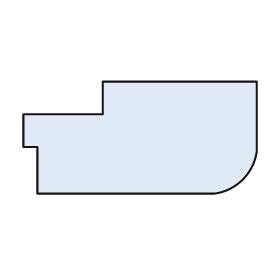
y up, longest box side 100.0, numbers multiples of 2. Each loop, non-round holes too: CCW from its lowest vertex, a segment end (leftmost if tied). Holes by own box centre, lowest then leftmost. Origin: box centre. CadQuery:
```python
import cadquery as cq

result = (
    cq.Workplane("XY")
    .moveTo(-44.0, -24.0)
    .lineTo(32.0, -24.0)
    .threePointArc((44.0, -18.0), (50.0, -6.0))
    .lineTo(50.0, 24.0)
    .lineTo(-16.0, 24.0)
    .lineTo(-16.0, 10.0)
    .lineTo(-50.0, 10.0)
    .lineTo(-50.0, -4.0)
    .lineTo(-44.0, -4.0)
    .close()
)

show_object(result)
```